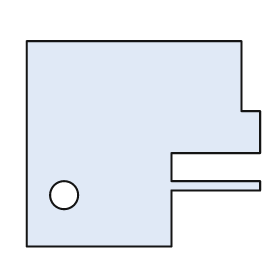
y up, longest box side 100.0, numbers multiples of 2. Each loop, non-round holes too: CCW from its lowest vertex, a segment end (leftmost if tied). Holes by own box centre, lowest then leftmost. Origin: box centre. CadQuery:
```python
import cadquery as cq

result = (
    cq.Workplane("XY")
    .moveTo(-50.0, -44.0)
    .lineTo(12.0, -44.0)
    .lineTo(12.0, -20.0)
    .lineTo(50.0, -20.0)
    .lineTo(50.0, -16.0)
    .lineTo(12.0, -16.0)
    .lineTo(12.0, -4.0)
    .lineTo(50.0, -4.0)
    .lineTo(50.0, 14.0)
    .lineTo(42.0, 14.0)
    .lineTo(42.0, 44.0)
    .lineTo(-50.0, 44.0)
    .close()
    .moveTo(-34.0, -22.0)
    .circle(6.0)
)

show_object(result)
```